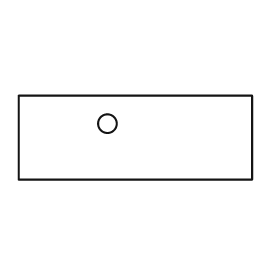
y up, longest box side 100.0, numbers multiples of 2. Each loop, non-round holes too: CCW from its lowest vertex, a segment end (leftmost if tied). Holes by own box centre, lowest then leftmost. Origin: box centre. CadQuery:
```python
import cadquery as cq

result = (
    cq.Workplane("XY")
    .moveTo(-50.0, -18.0)
    .lineTo(50.0, -18.0)
    .lineTo(50.0, 18.0)
    .lineTo(-50.0, 18.0)
    .close()
    .moveTo(-12.0, 6.0)
    .circle(4.0)
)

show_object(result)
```